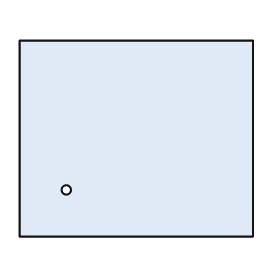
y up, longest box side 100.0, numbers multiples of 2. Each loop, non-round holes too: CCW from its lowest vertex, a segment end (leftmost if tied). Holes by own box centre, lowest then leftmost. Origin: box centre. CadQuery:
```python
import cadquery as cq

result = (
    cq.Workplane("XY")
    .moveTo(-50.0, -42.0)
    .lineTo(50.0, -42.0)
    .lineTo(50.0, 42.0)
    .lineTo(-50.0, 42.0)
    .close()
    .moveTo(-30.0, -22.0)
    .circle(2.0)
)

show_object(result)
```